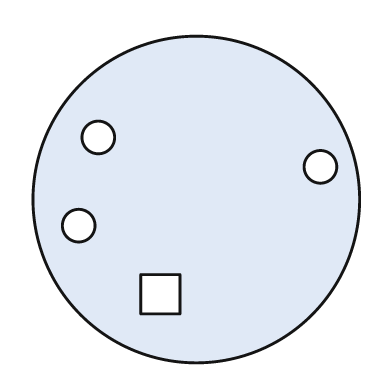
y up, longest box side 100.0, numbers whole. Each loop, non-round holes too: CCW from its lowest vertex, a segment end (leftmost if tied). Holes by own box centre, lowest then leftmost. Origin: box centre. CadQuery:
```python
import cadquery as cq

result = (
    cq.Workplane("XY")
    .moveTo(0.0, 0.0)
    .circle(50.0)
    .moveTo(-17.0, -35.0)
    .lineTo(-5.0, -35.0)
    .lineTo(-5.0, -23.0)
    .lineTo(-17.0, -23.0)
    .close()
    .moveTo(-36.0, -8.0)
    .circle(5.0)
    .moveTo(38.0, 10.0)
    .circle(5.0)
    .moveTo(-30.0, 19.0)
    .circle(5.0)
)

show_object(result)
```